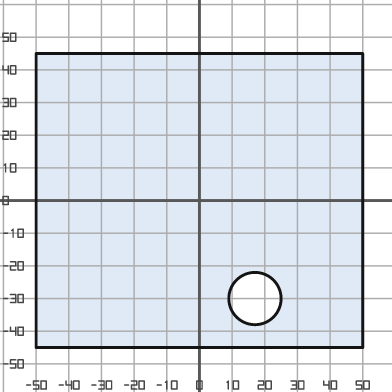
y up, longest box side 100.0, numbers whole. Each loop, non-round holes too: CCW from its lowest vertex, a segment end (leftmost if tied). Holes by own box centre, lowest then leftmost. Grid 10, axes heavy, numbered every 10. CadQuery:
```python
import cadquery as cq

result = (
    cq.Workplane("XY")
    .moveTo(-50.0, -45.0)
    .lineTo(50.0, -45.0)
    .lineTo(50.0, 45.0)
    .lineTo(-50.0, 45.0)
    .close()
    .moveTo(17.0, -30.0)
    .circle(8.0)
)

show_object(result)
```